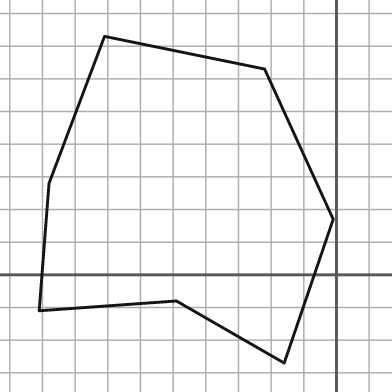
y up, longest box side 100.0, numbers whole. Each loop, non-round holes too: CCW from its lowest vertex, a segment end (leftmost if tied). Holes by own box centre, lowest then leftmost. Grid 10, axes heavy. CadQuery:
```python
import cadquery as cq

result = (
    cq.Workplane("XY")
    .moveTo(-16.0, -27.0)
    .lineTo(-1.0, 17.0)
    .lineTo(-22.0, 63.0)
    .lineTo(-71.0, 73.0)
    .lineTo(-88.0, 28.0)
    .lineTo(-91.0, -11.0)
    .lineTo(-49.0, -8.0)
    .close()
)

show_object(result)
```